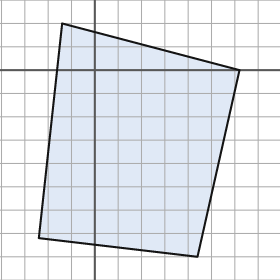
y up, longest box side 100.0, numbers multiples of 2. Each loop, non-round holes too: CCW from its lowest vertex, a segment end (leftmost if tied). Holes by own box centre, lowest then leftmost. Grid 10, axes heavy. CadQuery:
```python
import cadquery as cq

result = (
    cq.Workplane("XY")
    .moveTo(44.0, -80.0)
    .lineTo(62.0, 0.0)
    .lineTo(-14.0, 20.0)
    .lineTo(-24.0, -72.0)
    .close()
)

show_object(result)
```